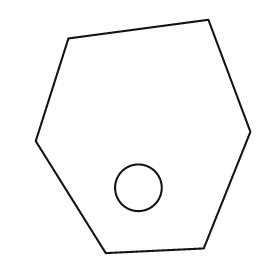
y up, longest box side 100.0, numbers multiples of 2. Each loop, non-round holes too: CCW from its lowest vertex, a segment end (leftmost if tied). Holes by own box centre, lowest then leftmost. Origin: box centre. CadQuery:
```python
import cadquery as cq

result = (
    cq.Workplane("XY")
    .moveTo(-16.0, -50.0)
    .lineTo(26.0, -48.0)
    .lineTo(46.0, 2.0)
    .lineTo(28.0, 50.0)
    .lineTo(-32.0, 42.0)
    .lineTo(-46.0, -2.0)
    .close()
    .moveTo(-2.0, -22.0)
    .circle(10.0)
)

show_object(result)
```